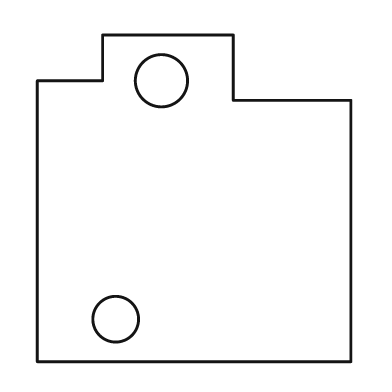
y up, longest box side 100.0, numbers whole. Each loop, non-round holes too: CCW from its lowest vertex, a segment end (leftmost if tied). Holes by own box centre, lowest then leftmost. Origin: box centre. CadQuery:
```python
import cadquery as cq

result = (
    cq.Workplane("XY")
    .moveTo(-48.0, -50.0)
    .lineTo(48.0, -50.0)
    .lineTo(48.0, 30.0)
    .lineTo(12.0, 30.0)
    .lineTo(12.0, 50.0)
    .lineTo(-28.0, 50.0)
    .lineTo(-28.0, 36.0)
    .lineTo(-48.0, 36.0)
    .close()
    .moveTo(-24.0, -37.0)
    .circle(7.0)
    .moveTo(-10.0, 36.0)
    .circle(8.0)
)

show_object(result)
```